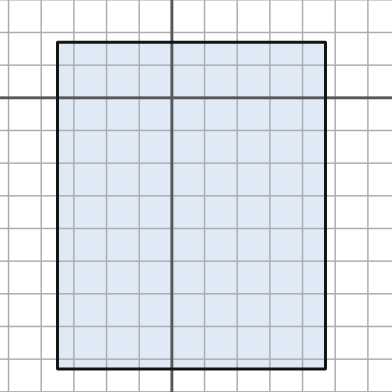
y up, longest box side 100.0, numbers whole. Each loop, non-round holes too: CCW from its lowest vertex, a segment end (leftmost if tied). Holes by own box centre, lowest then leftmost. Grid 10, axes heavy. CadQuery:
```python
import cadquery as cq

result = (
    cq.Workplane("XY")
    .moveTo(-35.0, -83.0)
    .lineTo(47.0, -83.0)
    .lineTo(47.0, 17.0)
    .lineTo(-35.0, 17.0)
    .close()
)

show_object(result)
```